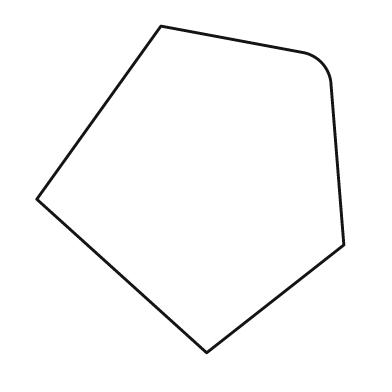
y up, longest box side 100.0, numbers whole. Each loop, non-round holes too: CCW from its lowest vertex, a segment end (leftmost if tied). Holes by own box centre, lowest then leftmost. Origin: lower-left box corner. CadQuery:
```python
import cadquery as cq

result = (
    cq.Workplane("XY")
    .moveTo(52.0, 0.0)
    .lineTo(94.0, 33.0)
    .lineTo(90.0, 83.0)
    .threePointArc((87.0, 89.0), (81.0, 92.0))
    .lineTo(38.0, 100.0)
    .lineTo(0.0, 47.0)
    .close()
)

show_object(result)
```